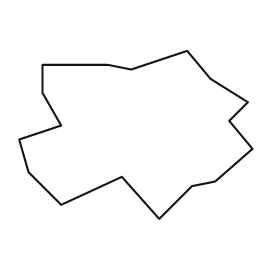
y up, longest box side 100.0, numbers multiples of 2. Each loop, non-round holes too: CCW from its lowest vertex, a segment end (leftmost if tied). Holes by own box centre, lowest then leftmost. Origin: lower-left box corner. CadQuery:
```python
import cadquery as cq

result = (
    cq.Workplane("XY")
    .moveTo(60.0, 0.0)
    .lineTo(74.0, 14.0)
    .lineTo(84.0, 16.0)
    .lineTo(100.0, 30.0)
    .lineTo(90.0, 42.0)
    .lineTo(98.0, 50.0)
    .lineTo(82.0, 60.0)
    .lineTo(72.0, 72.0)
    .lineTo(48.0, 64.0)
    .lineTo(38.0, 66.0)
    .lineTo(10.0, 66.0)
    .lineTo(10.0, 54.0)
    .lineTo(18.0, 40.0)
    .lineTo(0.0, 34.0)
    .lineTo(4.0, 20.0)
    .lineTo(18.0, 6.0)
    .lineTo(44.0, 18.0)
    .close()
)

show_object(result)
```